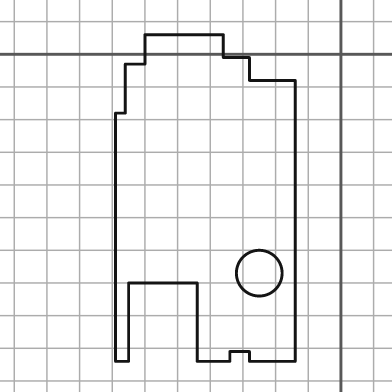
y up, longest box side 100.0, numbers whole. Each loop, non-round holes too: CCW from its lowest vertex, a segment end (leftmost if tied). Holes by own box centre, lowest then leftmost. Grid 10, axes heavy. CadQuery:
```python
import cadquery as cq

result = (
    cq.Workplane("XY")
    .moveTo(-69.0, -94.0)
    .lineTo(-65.0, -94.0)
    .lineTo(-65.0, -70.0)
    .lineTo(-44.0, -70.0)
    .lineTo(-44.0, -94.0)
    .lineTo(-34.0, -94.0)
    .lineTo(-34.0, -91.0)
    .lineTo(-28.0, -91.0)
    .lineTo(-28.0, -94.0)
    .lineTo(-14.0, -94.0)
    .lineTo(-14.0, -8.0)
    .lineTo(-28.0, -8.0)
    .lineTo(-28.0, -1.0)
    .lineTo(-36.0, -1.0)
    .lineTo(-36.0, 6.0)
    .lineTo(-60.0, 6.0)
    .lineTo(-60.0, -3.0)
    .lineTo(-66.0, -3.0)
    .lineTo(-66.0, -18.0)
    .lineTo(-69.0, -18.0)
    .close()
    .moveTo(-25.0, -67.0)
    .circle(7.0)
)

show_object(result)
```